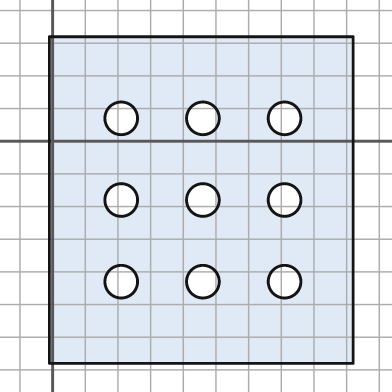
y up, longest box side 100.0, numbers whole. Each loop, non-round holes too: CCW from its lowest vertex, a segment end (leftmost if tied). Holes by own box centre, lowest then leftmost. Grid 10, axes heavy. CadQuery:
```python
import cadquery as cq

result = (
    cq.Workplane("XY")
    .moveTo(-1.0, -68.0)
    .lineTo(92.0, -68.0)
    .lineTo(92.0, 32.0)
    .lineTo(-1.0, 32.0)
    .close()
    .moveTo(21.0, -43.0)
    .circle(5.0)
    .moveTo(46.0, -43.0)
    .circle(5.0)
    .moveTo(71.0, -43.0)
    .circle(5.0)
    .moveTo(21.0, -18.0)
    .circle(5.0)
    .moveTo(46.0, -18.0)
    .circle(5.0)
    .moveTo(71.0, -18.0)
    .circle(5.0)
    .moveTo(21.0, 7.0)
    .circle(5.0)
    .moveTo(46.0, 7.0)
    .circle(5.0)
    .moveTo(71.0, 7.0)
    .circle(5.0)
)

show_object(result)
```